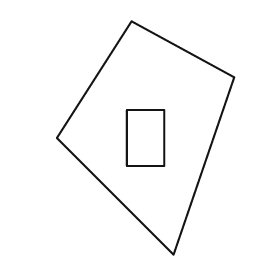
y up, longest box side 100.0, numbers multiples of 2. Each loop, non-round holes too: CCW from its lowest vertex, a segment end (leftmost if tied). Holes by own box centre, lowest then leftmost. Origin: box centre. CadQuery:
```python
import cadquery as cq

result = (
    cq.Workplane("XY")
    .moveTo(12.0, -50.0)
    .lineTo(38.0, 26.0)
    .lineTo(-6.0, 50.0)
    .lineTo(-38.0, 0.0)
    .close()
    .moveTo(-8.0, -12.0)
    .lineTo(8.0, -12.0)
    .lineTo(8.0, 12.0)
    .lineTo(-8.0, 12.0)
    .close()
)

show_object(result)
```